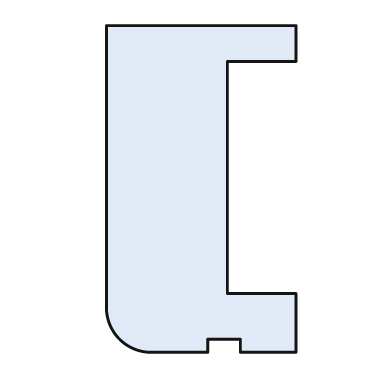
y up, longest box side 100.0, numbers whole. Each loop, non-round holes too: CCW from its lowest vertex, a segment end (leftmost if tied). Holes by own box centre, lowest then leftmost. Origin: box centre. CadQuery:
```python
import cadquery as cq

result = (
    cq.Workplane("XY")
    .moveTo(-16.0, -50.0)
    .lineTo(2.0, -50.0)
    .lineTo(2.0, -46.0)
    .lineTo(12.0, -46.0)
    .lineTo(12.0, -50.0)
    .lineTo(29.0, -50.0)
    .lineTo(29.0, -32.0)
    .lineTo(8.0, -32.0)
    .lineTo(8.0, 39.0)
    .lineTo(29.0, 39.0)
    .lineTo(29.0, 50.0)
    .lineTo(-29.0, 50.0)
    .lineTo(-29.0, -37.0)
    .threePointArc((-25.0, -46.0), (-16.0, -50.0))
    .close()
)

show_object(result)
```